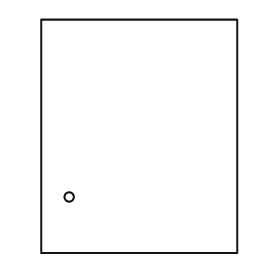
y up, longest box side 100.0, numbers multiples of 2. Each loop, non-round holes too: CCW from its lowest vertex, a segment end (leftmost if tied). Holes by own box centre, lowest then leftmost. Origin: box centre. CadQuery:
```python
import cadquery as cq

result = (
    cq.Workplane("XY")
    .moveTo(-42.0, -50.0)
    .lineTo(42.0, -50.0)
    .lineTo(42.0, 50.0)
    .lineTo(-42.0, 50.0)
    .close()
    .moveTo(-30.0, -26.0)
    .circle(2.0)
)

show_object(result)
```